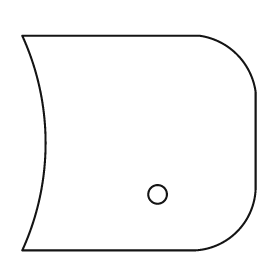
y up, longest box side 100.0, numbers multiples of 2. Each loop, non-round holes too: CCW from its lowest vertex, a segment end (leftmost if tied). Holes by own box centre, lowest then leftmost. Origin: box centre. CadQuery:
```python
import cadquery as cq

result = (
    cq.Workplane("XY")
    .moveTo(-50.0, -46.0)
    .lineTo(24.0, -46.0)
    .threePointArc((42.0, -38.0), (50.0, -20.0))
    .lineTo(50.0, 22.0)
    .threePointArc((42.0, 38.0), (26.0, 46.0))
    .lineTo(-50.0, 46.0)
    .threePointArc((-40.0, 0.0), (-50.0, -46.0))
    .close()
    .moveTo(8.0, -22.0)
    .circle(4.0)
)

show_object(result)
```